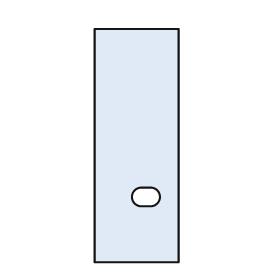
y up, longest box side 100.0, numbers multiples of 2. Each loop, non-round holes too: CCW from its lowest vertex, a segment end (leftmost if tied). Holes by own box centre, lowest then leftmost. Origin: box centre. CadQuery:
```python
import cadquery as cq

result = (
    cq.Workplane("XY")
    .moveTo(-18.0, -50.0)
    .lineTo(18.0, -50.0)
    .lineTo(18.0, 50.0)
    .lineTo(-18.0, 50.0)
    .close()
    .moveTo(2.0, -26.0)
    .lineTo(6.0, -26.0)
    .threePointArc((10.0, -22.0), (6.0, -18.0))
    .lineTo(2.0, -18.0)
    .threePointArc((-2.0, -22.0), (2.0, -26.0))
    .close()
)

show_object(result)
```